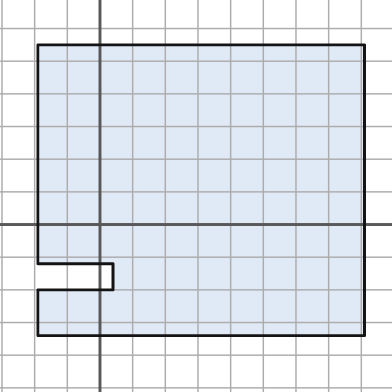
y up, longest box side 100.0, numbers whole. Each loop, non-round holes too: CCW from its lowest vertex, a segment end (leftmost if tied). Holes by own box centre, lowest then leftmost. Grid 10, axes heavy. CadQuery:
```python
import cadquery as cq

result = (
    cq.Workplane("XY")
    .moveTo(-19.0, -34.0)
    .lineTo(81.0, -34.0)
    .lineTo(81.0, 55.0)
    .lineTo(-19.0, 55.0)
    .lineTo(-19.0, -12.0)
    .lineTo(4.0, -12.0)
    .lineTo(4.0, -20.0)
    .lineTo(-19.0, -20.0)
    .close()
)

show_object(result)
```